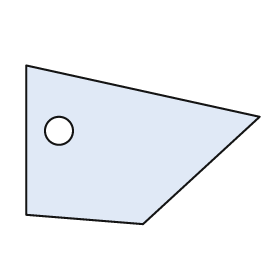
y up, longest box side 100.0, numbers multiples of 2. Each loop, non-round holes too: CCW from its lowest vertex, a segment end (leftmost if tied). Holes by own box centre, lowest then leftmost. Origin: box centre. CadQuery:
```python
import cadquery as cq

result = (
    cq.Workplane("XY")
    .moveTo(0.0, -34.0)
    .lineTo(50.0, 12.0)
    .lineTo(-50.0, 34.0)
    .lineTo(-50.0, -30.0)
    .close()
    .moveTo(-36.0, 6.0)
    .circle(6.0)
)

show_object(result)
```